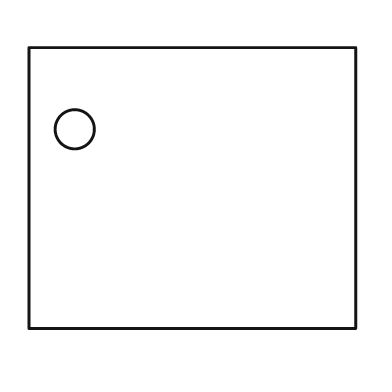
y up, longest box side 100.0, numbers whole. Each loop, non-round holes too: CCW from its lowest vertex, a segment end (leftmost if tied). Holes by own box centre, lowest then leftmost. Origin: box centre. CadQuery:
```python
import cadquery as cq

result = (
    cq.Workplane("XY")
    .moveTo(-50.0, -43.0)
    .lineTo(50.0, -43.0)
    .lineTo(50.0, 43.0)
    .lineTo(-50.0, 43.0)
    .close()
    .moveTo(-36.0, 18.0)
    .circle(6.0)
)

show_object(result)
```